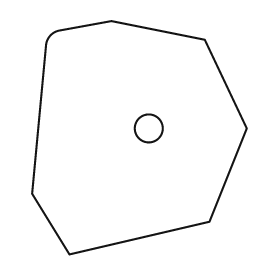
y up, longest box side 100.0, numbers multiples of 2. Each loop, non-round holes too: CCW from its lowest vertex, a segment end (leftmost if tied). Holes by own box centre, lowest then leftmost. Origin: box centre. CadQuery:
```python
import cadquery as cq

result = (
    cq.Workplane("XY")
    .moveTo(-30.0, -50.0)
    .lineTo(30.0, -36.0)
    .lineTo(46.0, 4.0)
    .lineTo(28.0, 42.0)
    .lineTo(-12.0, 50.0)
    .lineTo(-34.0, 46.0)
    .threePointArc((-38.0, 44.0), (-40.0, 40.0))
    .lineTo(-46.0, -24.0)
    .close()
    .moveTo(4.0, 4.0)
    .circle(6.0)
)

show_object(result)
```